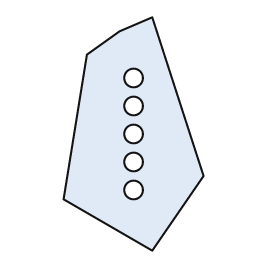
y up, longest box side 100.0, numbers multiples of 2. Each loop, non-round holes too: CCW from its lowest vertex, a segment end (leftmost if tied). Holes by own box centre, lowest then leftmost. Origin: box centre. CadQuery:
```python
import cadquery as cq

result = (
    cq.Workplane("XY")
    .moveTo(8.0, -50.0)
    .lineTo(30.0, -18.0)
    .lineTo(8.0, 50.0)
    .lineTo(-6.0, 44.0)
    .lineTo(-20.0, 34.0)
    .lineTo(-30.0, -28.0)
    .close()
    .moveTo(0.0, -24.0)
    .circle(4.0)
    .moveTo(0.0, -12.0)
    .circle(4.0)
    .moveTo(0.0, 0.0)
    .circle(4.0)
    .moveTo(0.0, 12.0)
    .circle(4.0)
    .moveTo(0.0, 24.0)
    .circle(4.0)
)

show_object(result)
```